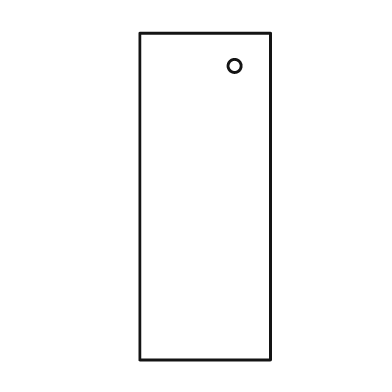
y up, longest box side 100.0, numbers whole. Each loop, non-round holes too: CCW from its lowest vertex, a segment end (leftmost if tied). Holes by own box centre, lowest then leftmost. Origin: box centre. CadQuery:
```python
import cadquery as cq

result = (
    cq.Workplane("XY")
    .moveTo(-20.0, -50.0)
    .lineTo(20.0, -50.0)
    .lineTo(20.0, 50.0)
    .lineTo(-20.0, 50.0)
    .close()
    .moveTo(9.0, 40.0)
    .circle(2.0)
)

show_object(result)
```